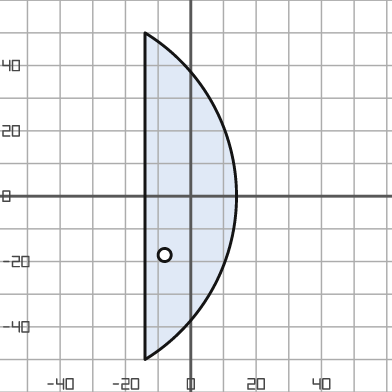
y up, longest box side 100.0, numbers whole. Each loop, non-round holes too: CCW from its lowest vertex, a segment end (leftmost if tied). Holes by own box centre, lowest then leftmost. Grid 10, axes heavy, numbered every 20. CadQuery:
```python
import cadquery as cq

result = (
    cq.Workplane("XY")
    .moveTo(-14.0, -50.0)
    .threePointArc((14.0, 0.0), (-14.0, 50.0))
    .close()
    .moveTo(-8.0, -18.0)
    .circle(2.0)
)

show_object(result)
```